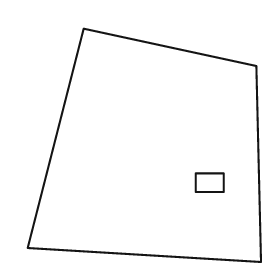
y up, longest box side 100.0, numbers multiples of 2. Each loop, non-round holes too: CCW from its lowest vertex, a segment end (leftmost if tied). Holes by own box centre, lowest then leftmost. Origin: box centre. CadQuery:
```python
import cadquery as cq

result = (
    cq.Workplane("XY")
    .moveTo(50.0, -50.0)
    .lineTo(48.0, 34.0)
    .lineTo(-26.0, 50.0)
    .lineTo(-50.0, -44.0)
    .close()
    .moveTo(22.0, -20.0)
    .lineTo(34.0, -20.0)
    .lineTo(34.0, -12.0)
    .lineTo(22.0, -12.0)
    .close()
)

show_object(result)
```